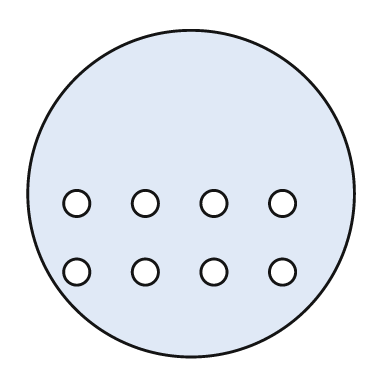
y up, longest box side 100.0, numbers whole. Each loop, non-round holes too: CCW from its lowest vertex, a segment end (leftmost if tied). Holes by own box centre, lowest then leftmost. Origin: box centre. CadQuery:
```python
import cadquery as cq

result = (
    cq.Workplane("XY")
    .moveTo(0.0, 0.0)
    .circle(50.0)
    .moveTo(-35.0, -24.0)
    .circle(4.0)
    .moveTo(-14.0, -24.0)
    .circle(4.0)
    .moveTo(7.0, -24.0)
    .circle(4.0)
    .moveTo(28.0, -24.0)
    .circle(4.0)
    .moveTo(-35.0, -3.0)
    .circle(4.0)
    .moveTo(-14.0, -3.0)
    .circle(4.0)
    .moveTo(7.0, -3.0)
    .circle(4.0)
    .moveTo(28.0, -3.0)
    .circle(4.0)
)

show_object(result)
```